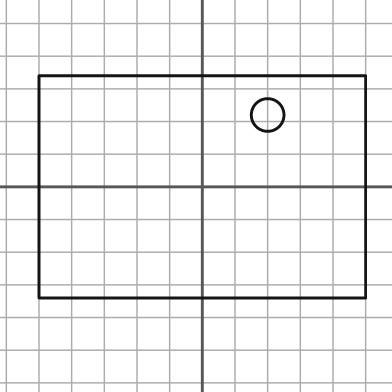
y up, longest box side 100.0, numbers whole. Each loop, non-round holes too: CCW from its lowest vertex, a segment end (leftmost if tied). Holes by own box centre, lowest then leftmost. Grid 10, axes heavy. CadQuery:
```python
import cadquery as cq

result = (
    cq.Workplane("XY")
    .moveTo(-50.0, -34.0)
    .lineTo(50.0, -34.0)
    .lineTo(50.0, 34.0)
    .lineTo(-50.0, 34.0)
    .close()
    .moveTo(20.0, 22.0)
    .circle(5.0)
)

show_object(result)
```